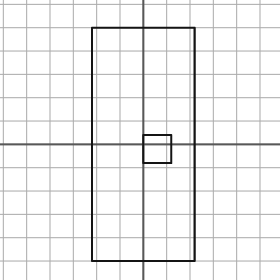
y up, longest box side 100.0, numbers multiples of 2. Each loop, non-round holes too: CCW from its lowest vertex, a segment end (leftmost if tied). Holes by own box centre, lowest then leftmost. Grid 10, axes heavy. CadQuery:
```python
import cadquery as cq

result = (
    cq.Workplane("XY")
    .moveTo(-22.0, -50.0)
    .lineTo(22.0, -50.0)
    .lineTo(22.0, 50.0)
    .lineTo(-22.0, 50.0)
    .close()
    .moveTo(0.0, -8.0)
    .lineTo(12.0, -8.0)
    .lineTo(12.0, 4.0)
    .lineTo(0.0, 4.0)
    .close()
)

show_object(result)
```